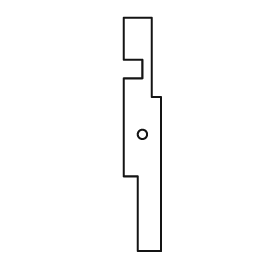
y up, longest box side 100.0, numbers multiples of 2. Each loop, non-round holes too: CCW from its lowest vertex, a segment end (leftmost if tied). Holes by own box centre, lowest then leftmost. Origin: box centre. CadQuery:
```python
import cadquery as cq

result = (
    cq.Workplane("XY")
    .moveTo(-2.0, -50.0)
    .lineTo(8.0, -50.0)
    .lineTo(8.0, 16.0)
    .lineTo(4.0, 16.0)
    .lineTo(4.0, 50.0)
    .lineTo(-8.0, 50.0)
    .lineTo(-8.0, 32.0)
    .lineTo(0.0, 32.0)
    .lineTo(0.0, 24.0)
    .lineTo(-8.0, 24.0)
    .lineTo(-8.0, -18.0)
    .lineTo(-2.0, -18.0)
    .close()
    .moveTo(0.0, 0.0)
    .circle(2.0)
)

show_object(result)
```